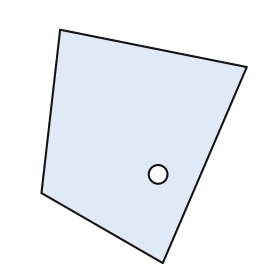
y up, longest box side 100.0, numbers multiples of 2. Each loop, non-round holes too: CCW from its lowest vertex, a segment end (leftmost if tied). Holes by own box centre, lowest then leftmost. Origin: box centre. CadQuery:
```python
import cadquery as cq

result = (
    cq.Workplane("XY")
    .moveTo(8.0, -50.0)
    .lineTo(44.0, 34.0)
    .lineTo(-36.0, 50.0)
    .lineTo(-44.0, -20.0)
    .close()
    .moveTo(6.0, -12.0)
    .circle(4.0)
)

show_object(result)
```